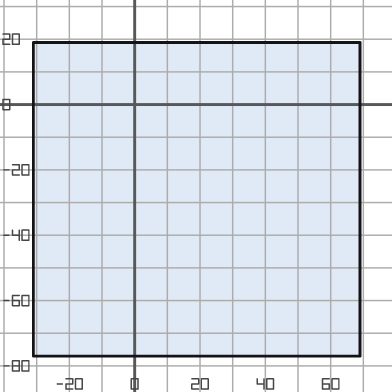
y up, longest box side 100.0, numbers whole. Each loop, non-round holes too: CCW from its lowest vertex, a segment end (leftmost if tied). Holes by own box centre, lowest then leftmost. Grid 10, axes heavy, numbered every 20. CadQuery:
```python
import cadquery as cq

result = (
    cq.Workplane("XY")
    .moveTo(-31.0, -77.0)
    .lineTo(69.0, -77.0)
    .lineTo(69.0, 19.0)
    .lineTo(-31.0, 19.0)
    .close()
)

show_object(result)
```